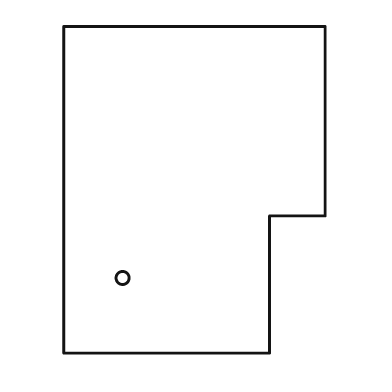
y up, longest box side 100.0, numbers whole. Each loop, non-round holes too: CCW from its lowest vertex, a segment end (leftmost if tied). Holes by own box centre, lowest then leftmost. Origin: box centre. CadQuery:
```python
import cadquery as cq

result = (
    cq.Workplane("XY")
    .moveTo(-40.0, -50.0)
    .lineTo(23.0, -50.0)
    .lineTo(23.0, -8.0)
    .lineTo(40.0, -8.0)
    .lineTo(40.0, 50.0)
    .lineTo(-40.0, 50.0)
    .close()
    .moveTo(-22.0, -27.0)
    .circle(2.0)
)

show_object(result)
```